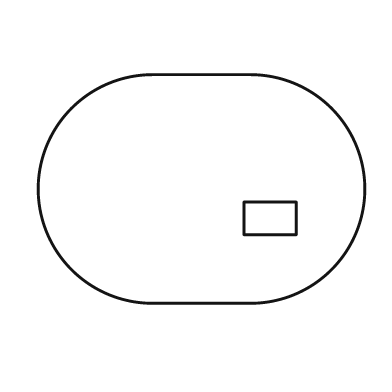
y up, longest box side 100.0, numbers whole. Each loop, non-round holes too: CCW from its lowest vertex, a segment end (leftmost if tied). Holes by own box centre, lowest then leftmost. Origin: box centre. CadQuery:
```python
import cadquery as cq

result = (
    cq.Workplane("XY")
    .moveTo(-15.0, -35.0)
    .lineTo(15.0, -35.0)
    .threePointArc((50.0, 0.0), (15.0, 35.0))
    .lineTo(-15.0, 35.0)
    .threePointArc((-50.0, 0.0), (-15.0, -35.0))
    .close()
    .moveTo(13.0, -14.0)
    .lineTo(29.0, -14.0)
    .lineTo(29.0, -4.0)
    .lineTo(13.0, -4.0)
    .close()
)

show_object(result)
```